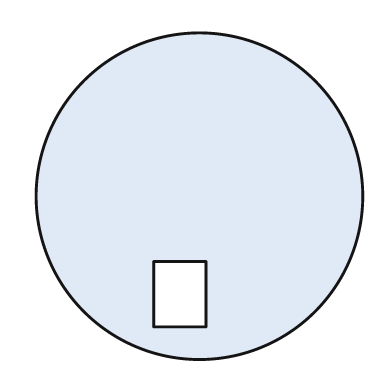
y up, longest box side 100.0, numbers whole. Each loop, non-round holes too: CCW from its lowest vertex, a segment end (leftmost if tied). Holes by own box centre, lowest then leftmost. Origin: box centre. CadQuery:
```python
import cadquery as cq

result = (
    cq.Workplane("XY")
    .moveTo(0.0, 0.0)
    .circle(50.0)
    .moveTo(-14.0, -40.0)
    .lineTo(2.0, -40.0)
    .lineTo(2.0, -20.0)
    .lineTo(-14.0, -20.0)
    .close()
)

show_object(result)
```